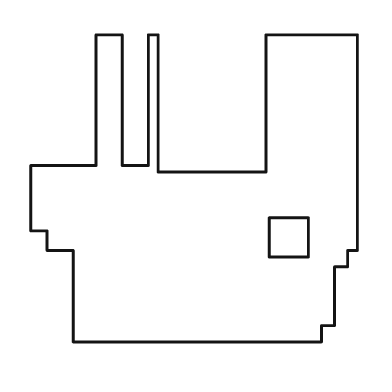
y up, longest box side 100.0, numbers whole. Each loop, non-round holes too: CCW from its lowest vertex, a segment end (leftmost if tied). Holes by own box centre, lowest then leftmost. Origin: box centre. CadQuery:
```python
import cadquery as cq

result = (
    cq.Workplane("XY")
    .moveTo(-37.0, -47.0)
    .lineTo(39.0, -47.0)
    .lineTo(39.0, -42.0)
    .lineTo(43.0, -42.0)
    .lineTo(43.0, -24.0)
    .lineTo(47.0, -24.0)
    .lineTo(47.0, -19.0)
    .lineTo(50.0, -19.0)
    .lineTo(50.0, 47.0)
    .lineTo(22.0, 47.0)
    .lineTo(22.0, 5.0)
    .lineTo(-11.0, 5.0)
    .lineTo(-11.0, 47.0)
    .lineTo(-14.0, 47.0)
    .lineTo(-14.0, 7.0)
    .lineTo(-22.0, 7.0)
    .lineTo(-22.0, 47.0)
    .lineTo(-30.0, 47.0)
    .lineTo(-30.0, 7.0)
    .lineTo(-50.0, 7.0)
    .lineTo(-50.0, -13.0)
    .lineTo(-45.0, -13.0)
    .lineTo(-45.0, -19.0)
    .lineTo(-37.0, -19.0)
    .close()
    .moveTo(23.0, -21.0)
    .lineTo(35.0, -21.0)
    .lineTo(35.0, -9.0)
    .lineTo(23.0, -9.0)
    .close()
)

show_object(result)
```